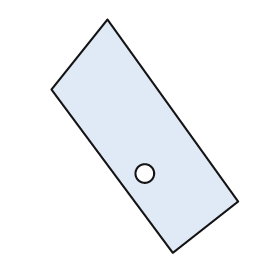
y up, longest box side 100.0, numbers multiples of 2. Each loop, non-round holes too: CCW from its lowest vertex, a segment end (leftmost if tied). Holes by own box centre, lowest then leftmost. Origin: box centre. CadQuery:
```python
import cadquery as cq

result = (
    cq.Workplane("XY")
    .moveTo(12.0, -50.0)
    .lineTo(40.0, -28.0)
    .lineTo(-16.0, 50.0)
    .lineTo(-40.0, 20.0)
    .close()
    .moveTo(0.0, -16.0)
    .circle(4.0)
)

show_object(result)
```